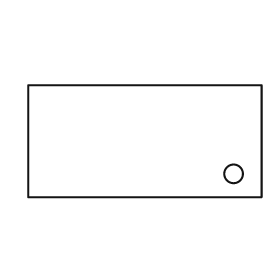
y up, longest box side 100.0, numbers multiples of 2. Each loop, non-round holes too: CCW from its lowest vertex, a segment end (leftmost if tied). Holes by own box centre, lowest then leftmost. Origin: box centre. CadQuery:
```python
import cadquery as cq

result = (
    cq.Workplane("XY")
    .moveTo(-50.0, -24.0)
    .lineTo(50.0, -24.0)
    .lineTo(50.0, 24.0)
    .lineTo(-50.0, 24.0)
    .close()
    .moveTo(38.0, -14.0)
    .circle(4.0)
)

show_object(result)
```